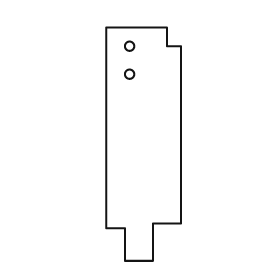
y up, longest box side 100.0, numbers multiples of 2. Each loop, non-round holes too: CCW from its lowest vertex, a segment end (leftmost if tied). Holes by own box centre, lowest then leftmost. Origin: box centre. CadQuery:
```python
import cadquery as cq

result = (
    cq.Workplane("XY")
    .moveTo(-8.0, -50.0)
    .lineTo(4.0, -50.0)
    .lineTo(4.0, -34.0)
    .lineTo(16.0, -34.0)
    .lineTo(16.0, 42.0)
    .lineTo(10.0, 42.0)
    .lineTo(10.0, 50.0)
    .lineTo(-16.0, 50.0)
    .lineTo(-16.0, -36.0)
    .lineTo(-8.0, -36.0)
    .close()
    .moveTo(-6.0, 30.0)
    .circle(2.0)
    .moveTo(-6.0, 42.0)
    .circle(2.0)
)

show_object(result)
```